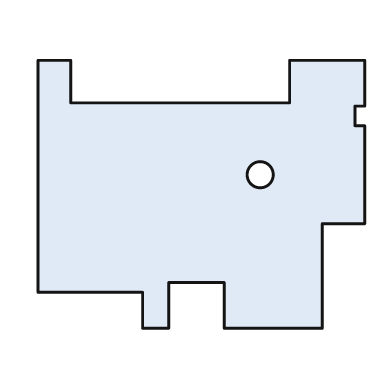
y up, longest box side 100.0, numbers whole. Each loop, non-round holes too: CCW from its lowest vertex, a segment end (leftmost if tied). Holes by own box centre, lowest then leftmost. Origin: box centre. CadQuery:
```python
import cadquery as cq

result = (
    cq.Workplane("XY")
    .moveTo(-18.0, -41.0)
    .lineTo(-10.0, -41.0)
    .lineTo(-10.0, -27.0)
    .lineTo(7.0, -27.0)
    .lineTo(7.0, -41.0)
    .lineTo(37.0, -41.0)
    .lineTo(37.0, -9.0)
    .lineTo(50.0, -9.0)
    .lineTo(50.0, 21.0)
    .lineTo(47.0, 21.0)
    .lineTo(47.0, 27.0)
    .lineTo(50.0, 27.0)
    .lineTo(50.0, 41.0)
    .lineTo(27.0, 41.0)
    .lineTo(27.0, 28.0)
    .lineTo(-40.0, 28.0)
    .lineTo(-40.0, 41.0)
    .lineTo(-50.0, 41.0)
    .lineTo(-50.0, -30.0)
    .lineTo(-18.0, -30.0)
    .close()
    .moveTo(18.0, 6.0)
    .circle(4.0)
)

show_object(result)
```